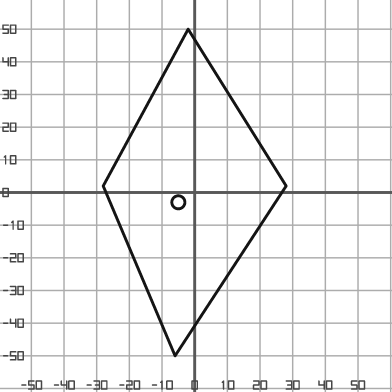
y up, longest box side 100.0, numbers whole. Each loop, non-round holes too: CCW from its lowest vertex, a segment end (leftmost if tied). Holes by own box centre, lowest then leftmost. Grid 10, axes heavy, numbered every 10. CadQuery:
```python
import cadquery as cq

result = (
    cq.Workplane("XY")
    .moveTo(-6.0, -50.0)
    .lineTo(28.0, 2.0)
    .lineTo(-2.0, 50.0)
    .lineTo(-28.0, 2.0)
    .close()
    .moveTo(-5.0, -3.0)
    .circle(2.0)
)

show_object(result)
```